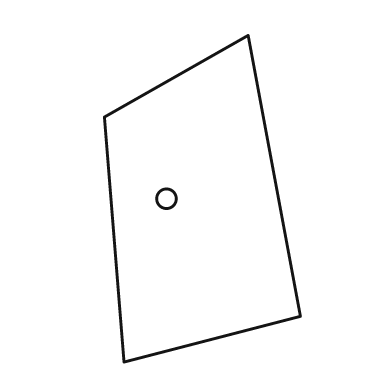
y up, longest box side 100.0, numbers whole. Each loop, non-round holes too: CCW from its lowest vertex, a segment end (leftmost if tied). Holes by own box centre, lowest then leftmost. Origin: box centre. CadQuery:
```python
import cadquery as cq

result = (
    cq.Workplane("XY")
    .moveTo(-24.0, -50.0)
    .lineTo(30.0, -36.0)
    .lineTo(14.0, 50.0)
    .lineTo(-30.0, 25.0)
    .close()
    .moveTo(-11.0, 0.0)
    .circle(3.0)
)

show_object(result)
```